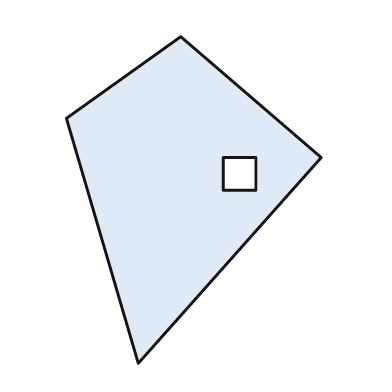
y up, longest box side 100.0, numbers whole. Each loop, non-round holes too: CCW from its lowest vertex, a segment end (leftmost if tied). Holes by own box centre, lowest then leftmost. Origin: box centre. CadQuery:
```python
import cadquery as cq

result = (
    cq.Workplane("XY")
    .moveTo(-17.0, -50.0)
    .lineTo(39.0, 13.0)
    .lineTo(-4.0, 50.0)
    .lineTo(-39.0, 25.0)
    .close()
    .moveTo(9.0, 3.0)
    .lineTo(19.0, 3.0)
    .lineTo(19.0, 13.0)
    .lineTo(9.0, 13.0)
    .close()
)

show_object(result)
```